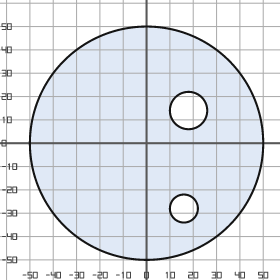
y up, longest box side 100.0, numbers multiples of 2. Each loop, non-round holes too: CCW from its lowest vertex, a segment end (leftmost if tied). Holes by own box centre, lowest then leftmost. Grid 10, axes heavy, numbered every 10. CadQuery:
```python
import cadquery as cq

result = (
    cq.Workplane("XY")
    .moveTo(0.0, 0.0)
    .circle(50.0)
    .moveTo(16.0, -28.0)
    .circle(6.0)
    .moveTo(18.0, 14.0)
    .circle(8.0)
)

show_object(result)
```